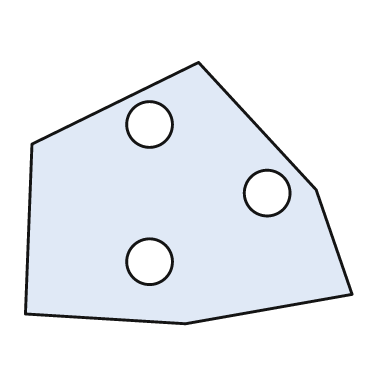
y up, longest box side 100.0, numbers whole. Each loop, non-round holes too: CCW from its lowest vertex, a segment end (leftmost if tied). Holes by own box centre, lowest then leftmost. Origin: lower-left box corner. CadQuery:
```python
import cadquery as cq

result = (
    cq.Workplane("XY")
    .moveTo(49.0, 0.0)
    .lineTo(100.0, 9.0)
    .lineTo(89.0, 41.0)
    .lineTo(53.0, 80.0)
    .lineTo(2.0, 55.0)
    .lineTo(0.0, 3.0)
    .close()
    .moveTo(38.0, 19.0)
    .circle(7.0)
    .moveTo(74.0, 40.0)
    .circle(7.0)
    .moveTo(38.0, 61.0)
    .circle(7.0)
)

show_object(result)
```